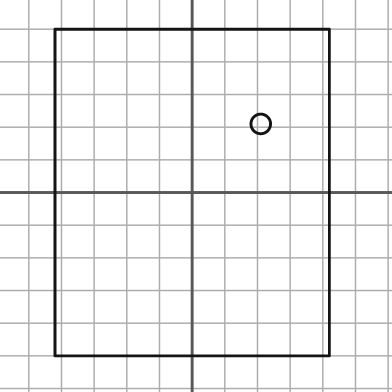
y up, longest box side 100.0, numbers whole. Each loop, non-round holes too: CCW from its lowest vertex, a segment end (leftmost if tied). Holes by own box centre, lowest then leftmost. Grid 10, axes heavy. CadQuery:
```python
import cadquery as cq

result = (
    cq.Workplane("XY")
    .moveTo(-42.0, -50.0)
    .lineTo(42.0, -50.0)
    .lineTo(42.0, 50.0)
    .lineTo(-42.0, 50.0)
    .close()
    .moveTo(21.0, 21.0)
    .circle(3.0)
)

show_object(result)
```